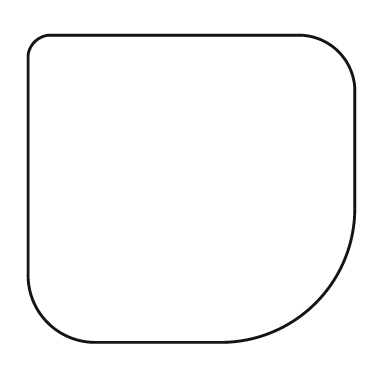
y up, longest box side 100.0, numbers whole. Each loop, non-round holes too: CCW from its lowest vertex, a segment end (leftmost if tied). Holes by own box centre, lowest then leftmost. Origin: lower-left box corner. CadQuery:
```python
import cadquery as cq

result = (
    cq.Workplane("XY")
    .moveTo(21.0, 0.0)
    .lineTo(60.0, 0.0)
    .threePointArc((88.0, 12.0), (100.0, 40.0))
    .lineTo(100.0, 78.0)
    .threePointArc((95.0, 89.0), (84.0, 94.0))
    .lineTo(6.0, 94.0)
    .threePointArc((2.0, 92.0), (0.0, 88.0))
    .lineTo(0.0, 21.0)
    .threePointArc((6.0, 6.0), (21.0, 0.0))
    .close()
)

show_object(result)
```